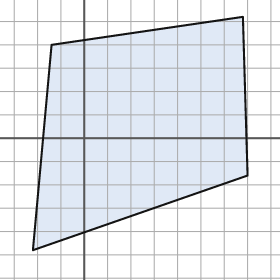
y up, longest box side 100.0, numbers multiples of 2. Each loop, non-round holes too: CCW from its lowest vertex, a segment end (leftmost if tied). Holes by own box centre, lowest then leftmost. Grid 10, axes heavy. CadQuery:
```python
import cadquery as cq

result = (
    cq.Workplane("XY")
    .moveTo(-22.0, -48.0)
    .lineTo(70.0, -16.0)
    .lineTo(68.0, 52.0)
    .lineTo(-14.0, 40.0)
    .close()
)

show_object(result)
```